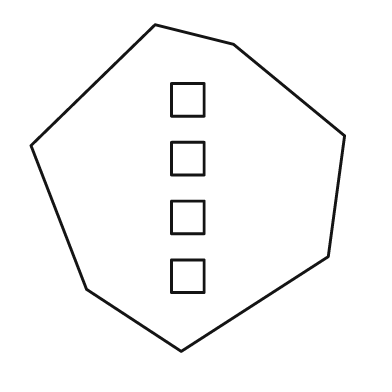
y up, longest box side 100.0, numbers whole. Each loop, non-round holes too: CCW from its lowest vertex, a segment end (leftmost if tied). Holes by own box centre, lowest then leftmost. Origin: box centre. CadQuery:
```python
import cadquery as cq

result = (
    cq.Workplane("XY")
    .moveTo(-2.0, -50.0)
    .lineTo(43.0, -21.0)
    .lineTo(48.0, 16.0)
    .lineTo(14.0, 44.0)
    .lineTo(-10.0, 50.0)
    .lineTo(-48.0, 13.0)
    .lineTo(-31.0, -31.0)
    .close()
    .moveTo(-5.0, -32.0)
    .lineTo(5.0, -32.0)
    .lineTo(5.0, -22.0)
    .lineTo(-5.0, -22.0)
    .close()
    .moveTo(-5.0, -14.0)
    .lineTo(5.0, -14.0)
    .lineTo(5.0, -4.0)
    .lineTo(-5.0, -4.0)
    .close()
    .moveTo(-5.0, 4.0)
    .lineTo(5.0, 4.0)
    .lineTo(5.0, 14.0)
    .lineTo(-5.0, 14.0)
    .close()
    .moveTo(-5.0, 22.0)
    .lineTo(5.0, 22.0)
    .lineTo(5.0, 32.0)
    .lineTo(-5.0, 32.0)
    .close()
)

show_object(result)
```